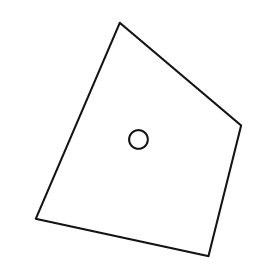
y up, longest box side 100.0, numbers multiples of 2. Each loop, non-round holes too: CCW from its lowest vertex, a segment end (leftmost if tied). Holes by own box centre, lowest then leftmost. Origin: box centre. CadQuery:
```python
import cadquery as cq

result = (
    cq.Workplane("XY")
    .moveTo(30.0, -50.0)
    .lineTo(44.0, 6.0)
    .lineTo(-8.0, 50.0)
    .lineTo(-44.0, -34.0)
    .close()
    .moveTo(0.0, 0.0)
    .circle(4.0)
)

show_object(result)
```